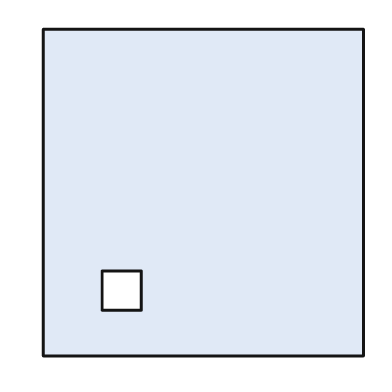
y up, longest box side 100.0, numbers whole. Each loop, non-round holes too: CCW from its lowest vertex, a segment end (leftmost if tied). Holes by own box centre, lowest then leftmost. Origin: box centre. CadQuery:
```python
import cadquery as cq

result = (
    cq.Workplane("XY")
    .moveTo(-49.0, -50.0)
    .lineTo(49.0, -50.0)
    .lineTo(49.0, 50.0)
    .lineTo(-49.0, 50.0)
    .close()
    .moveTo(-31.0, -36.0)
    .lineTo(-19.0, -36.0)
    .lineTo(-19.0, -24.0)
    .lineTo(-31.0, -24.0)
    .close()
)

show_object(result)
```